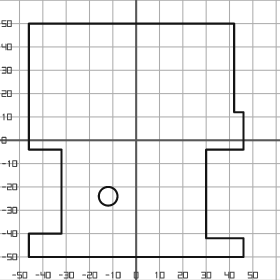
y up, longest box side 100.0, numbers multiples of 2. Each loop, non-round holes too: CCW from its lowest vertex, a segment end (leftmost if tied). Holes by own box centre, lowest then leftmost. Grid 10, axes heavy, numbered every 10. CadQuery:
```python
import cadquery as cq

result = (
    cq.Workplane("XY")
    .moveTo(-46.0, -50.0)
    .lineTo(46.0, -50.0)
    .lineTo(46.0, -42.0)
    .lineTo(30.0, -42.0)
    .lineTo(30.0, -4.0)
    .lineTo(46.0, -4.0)
    .lineTo(46.0, 12.0)
    .lineTo(42.0, 12.0)
    .lineTo(42.0, 50.0)
    .lineTo(-46.0, 50.0)
    .lineTo(-46.0, -4.0)
    .lineTo(-32.0, -4.0)
    .lineTo(-32.0, -40.0)
    .lineTo(-46.0, -40.0)
    .close()
    .moveTo(-12.0, -24.0)
    .circle(4.0)
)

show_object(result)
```